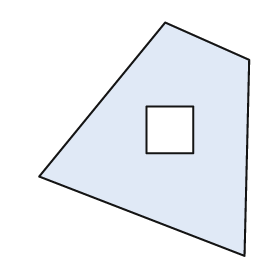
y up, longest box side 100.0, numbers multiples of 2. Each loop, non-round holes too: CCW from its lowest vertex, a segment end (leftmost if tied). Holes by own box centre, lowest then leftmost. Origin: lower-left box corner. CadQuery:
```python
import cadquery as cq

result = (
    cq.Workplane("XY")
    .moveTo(88.0, 0.0)
    .lineTo(90.0, 84.0)
    .lineTo(54.0, 100.0)
    .lineTo(0.0, 34.0)
    .close()
    .moveTo(46.0, 44.0)
    .lineTo(66.0, 44.0)
    .lineTo(66.0, 64.0)
    .lineTo(46.0, 64.0)
    .close()
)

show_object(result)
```